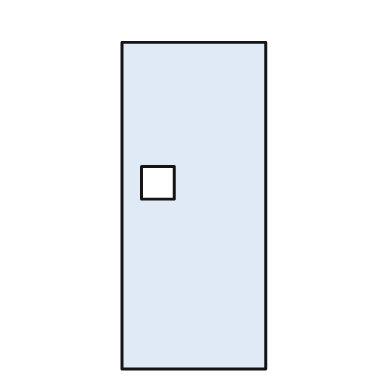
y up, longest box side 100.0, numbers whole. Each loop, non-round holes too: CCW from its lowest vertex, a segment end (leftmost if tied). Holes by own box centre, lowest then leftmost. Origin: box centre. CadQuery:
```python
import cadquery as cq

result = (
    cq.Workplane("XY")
    .moveTo(-22.0, -50.0)
    .lineTo(22.0, -50.0)
    .lineTo(22.0, 50.0)
    .lineTo(-22.0, 50.0)
    .close()
    .moveTo(-16.0, 2.0)
    .lineTo(-6.0, 2.0)
    .lineTo(-6.0, 12.0)
    .lineTo(-16.0, 12.0)
    .close()
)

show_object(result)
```